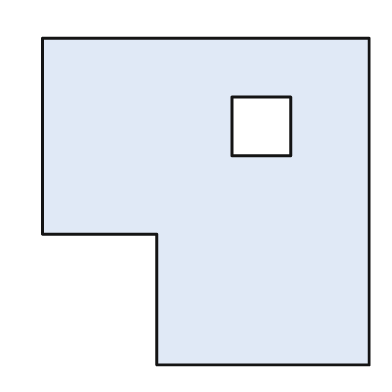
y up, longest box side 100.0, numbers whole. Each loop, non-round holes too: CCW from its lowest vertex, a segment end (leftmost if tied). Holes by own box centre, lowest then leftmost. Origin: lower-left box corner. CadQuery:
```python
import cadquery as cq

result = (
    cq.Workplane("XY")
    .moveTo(35.0, 0.0)
    .lineTo(100.0, 0.0)
    .lineTo(100.0, 100.0)
    .lineTo(0.0, 100.0)
    .lineTo(0.0, 40.0)
    .lineTo(35.0, 40.0)
    .close()
    .moveTo(58.0, 64.0)
    .lineTo(76.0, 64.0)
    .lineTo(76.0, 82.0)
    .lineTo(58.0, 82.0)
    .close()
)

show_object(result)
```